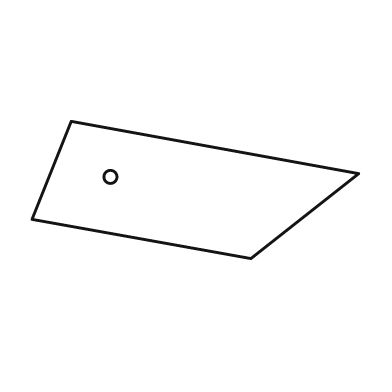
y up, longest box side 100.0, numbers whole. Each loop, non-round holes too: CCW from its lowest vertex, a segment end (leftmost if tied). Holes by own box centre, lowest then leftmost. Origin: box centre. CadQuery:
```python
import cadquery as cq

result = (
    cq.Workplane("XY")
    .moveTo(17.0, -21.0)
    .lineTo(50.0, 5.0)
    .lineTo(-38.0, 21.0)
    .lineTo(-50.0, -9.0)
    .close()
    .moveTo(-26.0, 4.0)
    .circle(2.0)
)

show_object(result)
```